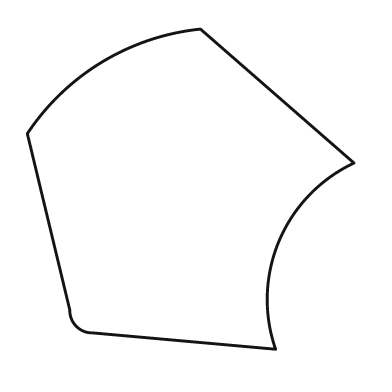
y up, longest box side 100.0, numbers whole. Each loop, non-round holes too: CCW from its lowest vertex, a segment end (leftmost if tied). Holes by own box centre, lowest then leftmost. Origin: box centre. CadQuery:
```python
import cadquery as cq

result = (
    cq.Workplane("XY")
    .moveTo(26.0, -49.0)
    .threePointArc((27.0, -16.0), (50.0, 8.0))
    .lineTo(3.0, 49.0)
    .threePointArc((-27.0, 39.0), (-50.0, 17.0))
    .lineTo(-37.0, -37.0)
    .threePointArc((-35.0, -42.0), (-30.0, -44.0))
    .close()
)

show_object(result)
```